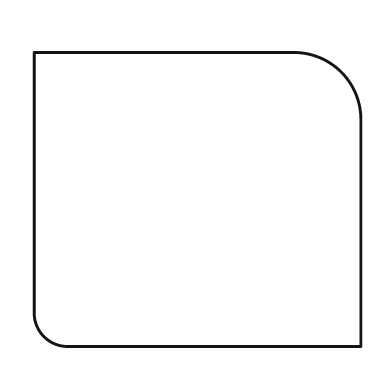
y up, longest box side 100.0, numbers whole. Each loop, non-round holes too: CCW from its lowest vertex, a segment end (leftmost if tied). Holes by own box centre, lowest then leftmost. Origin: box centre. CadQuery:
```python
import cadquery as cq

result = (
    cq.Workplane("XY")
    .moveTo(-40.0, -45.0)
    .lineTo(50.0, -45.0)
    .lineTo(50.0, 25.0)
    .threePointArc((44.0, 39.0), (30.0, 45.0))
    .lineTo(-50.0, 45.0)
    .lineTo(-50.0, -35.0)
    .threePointArc((-47.0, -42.0), (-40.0, -45.0))
    .close()
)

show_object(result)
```